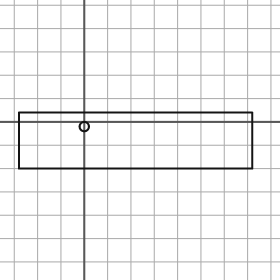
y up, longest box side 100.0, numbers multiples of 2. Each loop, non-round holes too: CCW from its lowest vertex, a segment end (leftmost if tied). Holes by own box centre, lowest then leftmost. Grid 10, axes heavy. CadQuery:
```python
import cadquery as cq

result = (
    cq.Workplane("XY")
    .moveTo(-28.0, -20.0)
    .lineTo(72.0, -20.0)
    .lineTo(72.0, 4.0)
    .lineTo(-28.0, 4.0)
    .close()
    .moveTo(0.0, -2.0)
    .circle(2.0)
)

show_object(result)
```